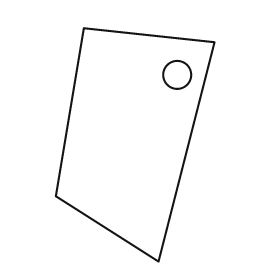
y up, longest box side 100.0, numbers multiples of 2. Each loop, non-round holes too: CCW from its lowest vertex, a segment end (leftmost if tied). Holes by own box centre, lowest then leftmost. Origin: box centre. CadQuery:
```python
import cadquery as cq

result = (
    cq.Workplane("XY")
    .moveTo(10.0, -50.0)
    .lineTo(34.0, 44.0)
    .lineTo(-22.0, 50.0)
    .lineTo(-34.0, -22.0)
    .close()
    .moveTo(18.0, 30.0)
    .circle(6.0)
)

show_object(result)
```